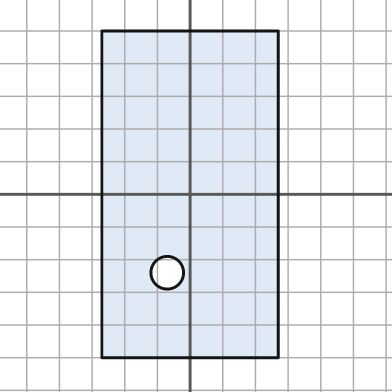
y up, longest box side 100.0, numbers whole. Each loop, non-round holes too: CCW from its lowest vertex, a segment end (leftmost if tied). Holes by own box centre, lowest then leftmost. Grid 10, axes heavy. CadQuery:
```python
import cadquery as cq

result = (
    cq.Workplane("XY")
    .moveTo(-27.0, -50.0)
    .lineTo(27.0, -50.0)
    .lineTo(27.0, 50.0)
    .lineTo(-27.0, 50.0)
    .close()
    .moveTo(-7.0, -24.0)
    .circle(5.0)
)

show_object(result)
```